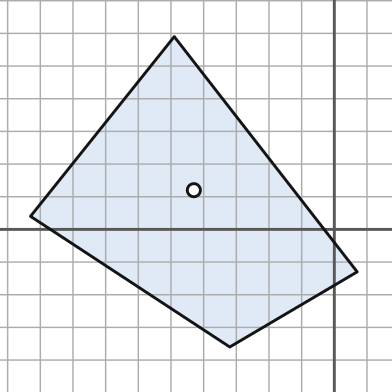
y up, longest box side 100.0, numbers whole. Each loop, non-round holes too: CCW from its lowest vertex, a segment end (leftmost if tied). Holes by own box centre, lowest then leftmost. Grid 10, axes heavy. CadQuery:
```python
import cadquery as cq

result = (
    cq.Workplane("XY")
    .moveTo(-32.0, -36.0)
    .lineTo(7.0, -13.0)
    .lineTo(-49.0, 59.0)
    .lineTo(-93.0, 4.0)
    .close()
    .moveTo(-43.0, 12.0)
    .circle(2.0)
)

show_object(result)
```